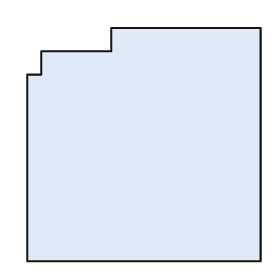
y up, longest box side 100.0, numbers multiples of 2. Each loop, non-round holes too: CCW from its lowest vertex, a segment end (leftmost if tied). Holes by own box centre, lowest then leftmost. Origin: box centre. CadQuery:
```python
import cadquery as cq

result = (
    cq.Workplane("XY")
    .moveTo(-50.0, -50.0)
    .lineTo(50.0, -50.0)
    .lineTo(50.0, 50.0)
    .lineTo(-14.0, 50.0)
    .lineTo(-14.0, 40.0)
    .lineTo(-44.0, 40.0)
    .lineTo(-44.0, 30.0)
    .lineTo(-50.0, 30.0)
    .close()
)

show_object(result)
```